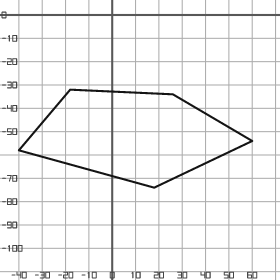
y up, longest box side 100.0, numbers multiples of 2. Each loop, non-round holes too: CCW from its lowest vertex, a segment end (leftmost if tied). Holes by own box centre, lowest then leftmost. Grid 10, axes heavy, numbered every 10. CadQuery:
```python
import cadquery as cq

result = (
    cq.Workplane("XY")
    .moveTo(18.0, -74.0)
    .lineTo(60.0, -54.0)
    .lineTo(26.0, -34.0)
    .lineTo(-18.0, -32.0)
    .lineTo(-40.0, -58.0)
    .close()
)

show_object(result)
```